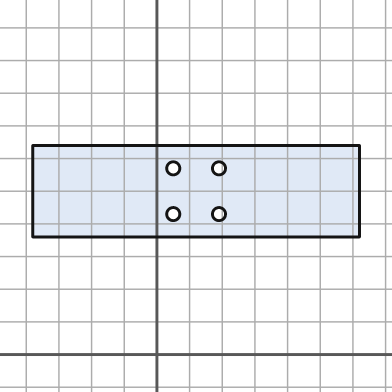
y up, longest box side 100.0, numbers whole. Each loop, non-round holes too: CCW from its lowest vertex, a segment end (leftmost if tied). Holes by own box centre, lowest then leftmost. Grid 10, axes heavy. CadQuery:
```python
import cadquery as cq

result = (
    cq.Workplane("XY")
    .moveTo(-38.0, 36.0)
    .lineTo(62.0, 36.0)
    .lineTo(62.0, 64.0)
    .lineTo(-38.0, 64.0)
    .close()
    .moveTo(5.0, 43.0)
    .circle(2.0)
    .moveTo(19.0, 43.0)
    .circle(2.0)
    .moveTo(5.0, 57.0)
    .circle(2.0)
    .moveTo(19.0, 57.0)
    .circle(2.0)
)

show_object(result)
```